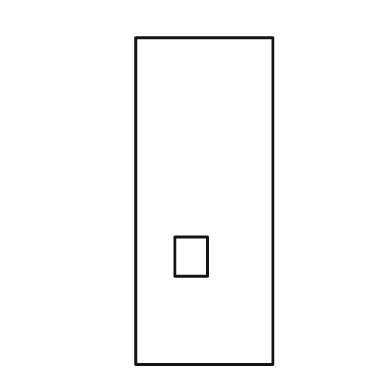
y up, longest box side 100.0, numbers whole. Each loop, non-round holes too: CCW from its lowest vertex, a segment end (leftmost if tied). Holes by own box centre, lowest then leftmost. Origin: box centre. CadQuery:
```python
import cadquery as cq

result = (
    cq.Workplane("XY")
    .moveTo(-21.0, -50.0)
    .lineTo(21.0, -50.0)
    .lineTo(21.0, 50.0)
    .lineTo(-21.0, 50.0)
    .close()
    .moveTo(-9.0, -23.0)
    .lineTo(1.0, -23.0)
    .lineTo(1.0, -11.0)
    .lineTo(-9.0, -11.0)
    .close()
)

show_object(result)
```